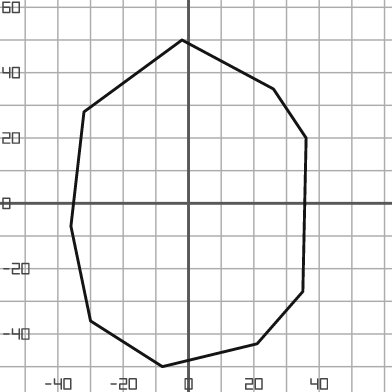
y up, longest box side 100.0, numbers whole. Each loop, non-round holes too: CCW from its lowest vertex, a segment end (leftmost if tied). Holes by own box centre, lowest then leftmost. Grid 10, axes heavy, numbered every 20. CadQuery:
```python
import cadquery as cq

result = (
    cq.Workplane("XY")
    .moveTo(-8.0, -50.0)
    .lineTo(21.0, -43.0)
    .lineTo(35.0, -27.0)
    .lineTo(36.0, 20.0)
    .lineTo(26.0, 35.0)
    .lineTo(-2.0, 50.0)
    .lineTo(-32.0, 28.0)
    .lineTo(-36.0, -7.0)
    .lineTo(-30.0, -36.0)
    .close()
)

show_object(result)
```